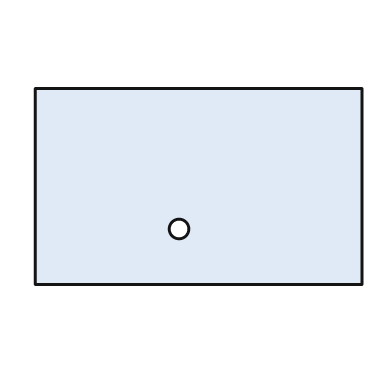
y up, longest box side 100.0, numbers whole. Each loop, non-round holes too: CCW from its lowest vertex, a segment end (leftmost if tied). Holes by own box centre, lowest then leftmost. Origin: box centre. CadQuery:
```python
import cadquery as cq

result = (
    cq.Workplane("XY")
    .moveTo(-50.0, -30.0)
    .lineTo(50.0, -30.0)
    .lineTo(50.0, 30.0)
    .lineTo(-50.0, 30.0)
    .close()
    .moveTo(-6.0, -13.0)
    .circle(3.0)
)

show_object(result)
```